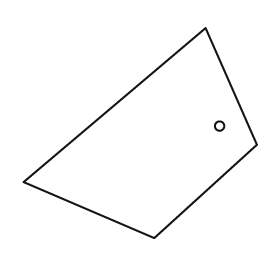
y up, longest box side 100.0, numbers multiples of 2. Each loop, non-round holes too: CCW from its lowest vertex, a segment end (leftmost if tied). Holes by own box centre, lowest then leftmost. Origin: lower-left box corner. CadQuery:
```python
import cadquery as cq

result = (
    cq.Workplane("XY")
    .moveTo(56.0, 0.0)
    .lineTo(100.0, 40.0)
    .lineTo(78.0, 90.0)
    .lineTo(0.0, 24.0)
    .close()
    .moveTo(84.0, 48.0)
    .circle(2.0)
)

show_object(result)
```